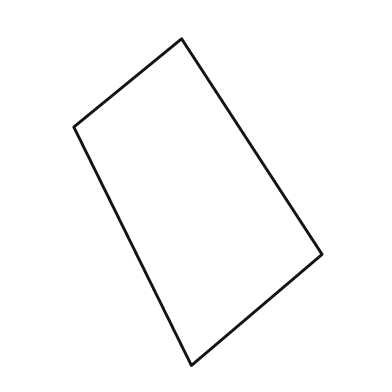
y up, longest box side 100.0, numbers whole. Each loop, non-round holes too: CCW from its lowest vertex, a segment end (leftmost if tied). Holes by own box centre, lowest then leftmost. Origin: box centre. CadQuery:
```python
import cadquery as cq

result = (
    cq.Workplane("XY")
    .moveTo(-2.0, -50.0)
    .lineTo(38.0, -16.0)
    .lineTo(-5.0, 50.0)
    .lineTo(-38.0, 23.0)
    .close()
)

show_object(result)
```